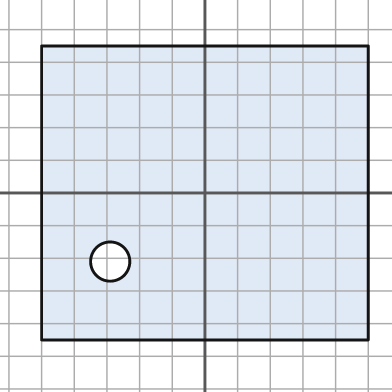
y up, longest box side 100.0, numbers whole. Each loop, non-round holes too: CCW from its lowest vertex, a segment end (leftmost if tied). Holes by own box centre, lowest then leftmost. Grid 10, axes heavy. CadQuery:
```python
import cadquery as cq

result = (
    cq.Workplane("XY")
    .moveTo(-50.0, -45.0)
    .lineTo(50.0, -45.0)
    .lineTo(50.0, 45.0)
    .lineTo(-50.0, 45.0)
    .close()
    .moveTo(-29.0, -21.0)
    .circle(6.0)
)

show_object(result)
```